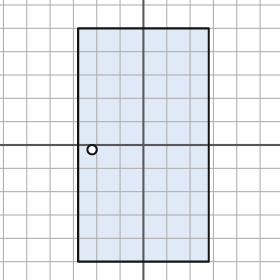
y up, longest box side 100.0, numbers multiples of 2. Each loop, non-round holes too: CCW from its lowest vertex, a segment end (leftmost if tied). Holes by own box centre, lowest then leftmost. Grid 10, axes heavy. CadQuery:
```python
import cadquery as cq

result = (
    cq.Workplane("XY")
    .moveTo(-28.0, -50.0)
    .lineTo(28.0, -50.0)
    .lineTo(28.0, 50.0)
    .lineTo(-28.0, 50.0)
    .close()
    .moveTo(-22.0, -2.0)
    .circle(2.0)
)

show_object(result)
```